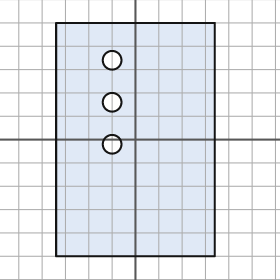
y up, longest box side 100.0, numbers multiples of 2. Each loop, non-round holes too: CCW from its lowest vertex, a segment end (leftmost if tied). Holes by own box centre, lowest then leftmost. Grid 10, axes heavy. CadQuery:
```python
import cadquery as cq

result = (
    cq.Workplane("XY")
    .moveTo(-34.0, -50.0)
    .lineTo(34.0, -50.0)
    .lineTo(34.0, 50.0)
    .lineTo(-34.0, 50.0)
    .close()
    .moveTo(-10.0, -2.0)
    .circle(4.0)
    .moveTo(-10.0, 16.0)
    .circle(4.0)
    .moveTo(-10.0, 34.0)
    .circle(4.0)
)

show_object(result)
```